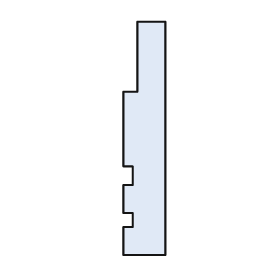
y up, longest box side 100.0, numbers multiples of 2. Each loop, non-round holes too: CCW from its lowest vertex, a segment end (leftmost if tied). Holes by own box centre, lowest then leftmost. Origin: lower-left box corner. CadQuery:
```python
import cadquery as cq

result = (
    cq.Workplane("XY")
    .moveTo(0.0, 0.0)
    .lineTo(18.0, 0.0)
    .lineTo(18.0, 100.0)
    .lineTo(6.0, 100.0)
    .lineTo(6.0, 70.0)
    .lineTo(0.0, 70.0)
    .lineTo(0.0, 38.0)
    .lineTo(4.0, 38.0)
    .lineTo(4.0, 30.0)
    .lineTo(0.0, 30.0)
    .lineTo(0.0, 18.0)
    .lineTo(4.0, 18.0)
    .lineTo(4.0, 12.0)
    .lineTo(0.0, 12.0)
    .close()
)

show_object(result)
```